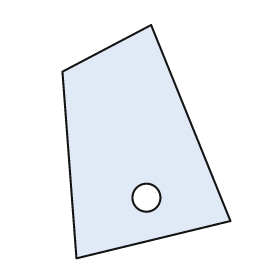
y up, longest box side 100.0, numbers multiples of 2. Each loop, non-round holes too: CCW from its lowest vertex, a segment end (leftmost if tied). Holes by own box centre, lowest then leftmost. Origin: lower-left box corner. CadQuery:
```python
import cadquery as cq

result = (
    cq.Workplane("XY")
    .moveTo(6.0, 0.0)
    .lineTo(72.0, 16.0)
    .lineTo(38.0, 100.0)
    .lineTo(0.0, 80.0)
    .close()
    .moveTo(36.0, 26.0)
    .circle(6.0)
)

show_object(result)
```